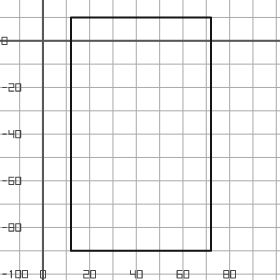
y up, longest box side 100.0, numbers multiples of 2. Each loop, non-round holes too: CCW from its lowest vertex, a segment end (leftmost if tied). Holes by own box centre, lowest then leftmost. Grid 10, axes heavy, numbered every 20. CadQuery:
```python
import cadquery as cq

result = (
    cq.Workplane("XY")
    .moveTo(12.0, -90.0)
    .lineTo(72.0, -90.0)
    .lineTo(72.0, 10.0)
    .lineTo(12.0, 10.0)
    .close()
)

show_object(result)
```